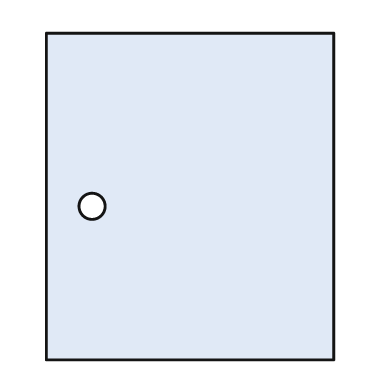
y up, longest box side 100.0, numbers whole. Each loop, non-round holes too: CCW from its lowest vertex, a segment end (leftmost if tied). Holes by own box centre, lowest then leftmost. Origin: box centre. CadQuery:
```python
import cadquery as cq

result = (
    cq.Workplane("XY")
    .moveTo(-44.0, -50.0)
    .lineTo(44.0, -50.0)
    .lineTo(44.0, 50.0)
    .lineTo(-44.0, 50.0)
    .close()
    .moveTo(-30.0, -3.0)
    .circle(4.0)
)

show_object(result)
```